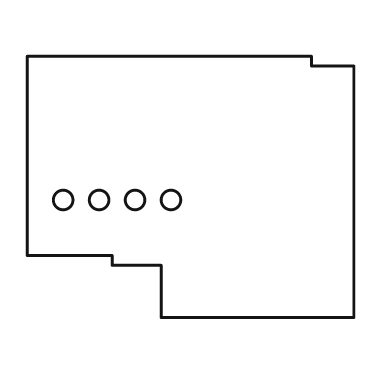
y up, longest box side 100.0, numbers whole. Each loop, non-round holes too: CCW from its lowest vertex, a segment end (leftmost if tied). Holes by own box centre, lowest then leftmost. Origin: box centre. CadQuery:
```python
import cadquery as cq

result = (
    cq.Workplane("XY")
    .moveTo(-9.0, -40.0)
    .lineTo(50.0, -40.0)
    .lineTo(50.0, 37.0)
    .lineTo(37.0, 37.0)
    .lineTo(37.0, 40.0)
    .lineTo(-50.0, 40.0)
    .lineTo(-50.0, -21.0)
    .lineTo(-24.0, -21.0)
    .lineTo(-24.0, -24.0)
    .lineTo(-9.0, -24.0)
    .close()
    .moveTo(-39.0, -4.0)
    .circle(3.0)
    .moveTo(-28.0, -4.0)
    .circle(3.0)
    .moveTo(-17.0, -4.0)
    .circle(3.0)
    .moveTo(-6.0, -4.0)
    .circle(3.0)
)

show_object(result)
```